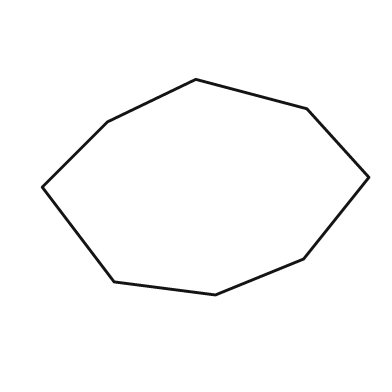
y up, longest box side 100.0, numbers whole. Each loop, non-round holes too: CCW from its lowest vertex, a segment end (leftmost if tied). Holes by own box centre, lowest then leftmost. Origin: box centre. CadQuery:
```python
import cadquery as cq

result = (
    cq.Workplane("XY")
    .moveTo(3.0, -33.0)
    .lineTo(30.0, -22.0)
    .lineTo(50.0, 3.0)
    .lineTo(31.0, 24.0)
    .lineTo(-3.0, 33.0)
    .lineTo(-30.0, 20.0)
    .lineTo(-50.0, 0.0)
    .lineTo(-28.0, -29.0)
    .close()
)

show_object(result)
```